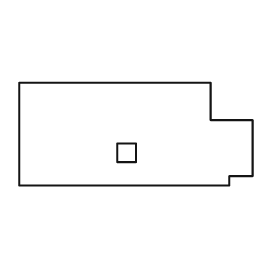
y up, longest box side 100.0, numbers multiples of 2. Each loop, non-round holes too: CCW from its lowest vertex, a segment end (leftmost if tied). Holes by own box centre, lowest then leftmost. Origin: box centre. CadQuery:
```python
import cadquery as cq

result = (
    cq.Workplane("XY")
    .moveTo(-50.0, -22.0)
    .lineTo(40.0, -22.0)
    .lineTo(40.0, -18.0)
    .lineTo(50.0, -18.0)
    .lineTo(50.0, 6.0)
    .lineTo(32.0, 6.0)
    .lineTo(32.0, 22.0)
    .lineTo(-50.0, 22.0)
    .close()
    .moveTo(-8.0, -12.0)
    .lineTo(0.0, -12.0)
    .lineTo(0.0, -4.0)
    .lineTo(-8.0, -4.0)
    .close()
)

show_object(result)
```